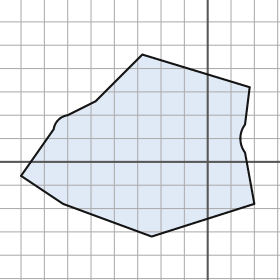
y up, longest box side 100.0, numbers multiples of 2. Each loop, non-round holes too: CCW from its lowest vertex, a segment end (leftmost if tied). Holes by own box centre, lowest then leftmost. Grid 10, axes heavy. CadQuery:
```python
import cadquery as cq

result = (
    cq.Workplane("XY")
    .moveTo(-24.0, -32.0)
    .lineTo(20.0, -18.0)
    .lineTo(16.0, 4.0)
    .threePointArc((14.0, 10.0), (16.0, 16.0))
    .lineTo(18.0, 32.0)
    .lineTo(-28.0, 46.0)
    .lineTo(-48.0, 26.0)
    .lineTo(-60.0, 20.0)
    .threePointArc((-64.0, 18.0), (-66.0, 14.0))
    .lineTo(-80.0, -6.0)
    .lineTo(-62.0, -18.0)
    .close()
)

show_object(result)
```